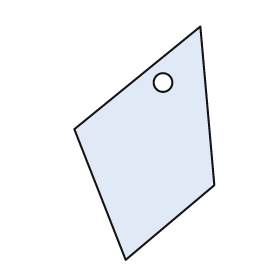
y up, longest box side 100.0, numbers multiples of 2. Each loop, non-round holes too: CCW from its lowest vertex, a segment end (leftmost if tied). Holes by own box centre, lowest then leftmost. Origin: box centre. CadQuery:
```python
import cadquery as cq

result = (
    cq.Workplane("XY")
    .moveTo(-8.0, -50.0)
    .lineTo(30.0, -18.0)
    .lineTo(24.0, 50.0)
    .lineTo(-30.0, 6.0)
    .close()
    .moveTo(8.0, 26.0)
    .circle(4.0)
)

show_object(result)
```